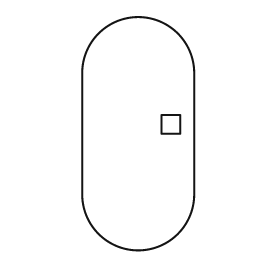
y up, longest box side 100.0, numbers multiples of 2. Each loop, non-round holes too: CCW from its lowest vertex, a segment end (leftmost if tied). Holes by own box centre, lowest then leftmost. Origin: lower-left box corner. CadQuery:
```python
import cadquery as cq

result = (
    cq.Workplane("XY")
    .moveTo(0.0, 24.0)
    .threePointArc((24.0, 0.0), (48.0, 24.0))
    .lineTo(48.0, 76.0)
    .threePointArc((24.0, 100.0), (0.0, 76.0))
    .close()
    .moveTo(34.0, 50.0)
    .lineTo(42.0, 50.0)
    .lineTo(42.0, 58.0)
    .lineTo(34.0, 58.0)
    .close()
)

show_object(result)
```